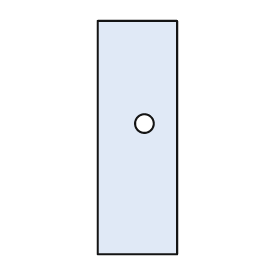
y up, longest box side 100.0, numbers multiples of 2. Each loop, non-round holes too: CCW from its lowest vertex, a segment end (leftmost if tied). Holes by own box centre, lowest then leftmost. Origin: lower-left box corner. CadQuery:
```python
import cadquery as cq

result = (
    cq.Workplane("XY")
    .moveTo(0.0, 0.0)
    .lineTo(34.0, 0.0)
    .lineTo(34.0, 100.0)
    .lineTo(0.0, 100.0)
    .close()
    .moveTo(20.0, 56.0)
    .circle(4.0)
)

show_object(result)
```